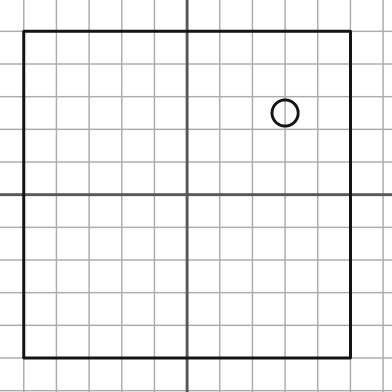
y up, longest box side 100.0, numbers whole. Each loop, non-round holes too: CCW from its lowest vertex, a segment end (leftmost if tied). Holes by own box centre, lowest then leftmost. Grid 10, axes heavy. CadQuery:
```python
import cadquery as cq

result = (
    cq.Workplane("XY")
    .moveTo(-50.0, -50.0)
    .lineTo(50.0, -50.0)
    .lineTo(50.0, 50.0)
    .lineTo(-50.0, 50.0)
    .close()
    .moveTo(30.0, 25.0)
    .circle(4.0)
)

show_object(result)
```